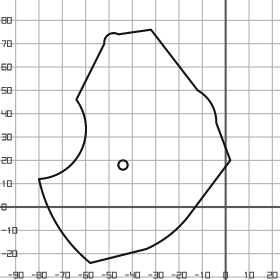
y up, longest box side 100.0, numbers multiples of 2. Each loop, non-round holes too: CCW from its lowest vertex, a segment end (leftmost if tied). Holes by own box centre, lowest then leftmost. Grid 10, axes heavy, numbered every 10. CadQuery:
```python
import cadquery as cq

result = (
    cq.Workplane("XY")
    .moveTo(-58.0, -24.0)
    .lineTo(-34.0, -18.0)
    .threePointArc((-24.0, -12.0), (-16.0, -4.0))
    .lineTo(2.0, 20.0)
    .lineTo(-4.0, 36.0)
    .threePointArc((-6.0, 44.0), (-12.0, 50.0))
    .lineTo(-32.0, 76.0)
    .lineTo(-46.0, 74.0)
    .threePointArc((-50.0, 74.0), (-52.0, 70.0))
    .lineTo(-64.0, 46.0)
    .threePointArc((-62.0, 24.0), (-80.0, 12.0))
    .threePointArc((-72.0, -8.0), (-58.0, -24.0))
    .close()
    .moveTo(-44.0, 18.0)
    .circle(2.0)
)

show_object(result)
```